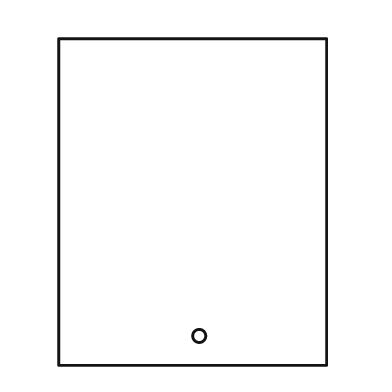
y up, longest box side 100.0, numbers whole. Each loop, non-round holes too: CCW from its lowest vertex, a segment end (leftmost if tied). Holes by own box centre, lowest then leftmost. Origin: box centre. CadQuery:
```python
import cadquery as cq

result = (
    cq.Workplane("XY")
    .moveTo(-41.0, -50.0)
    .lineTo(41.0, -50.0)
    .lineTo(41.0, 50.0)
    .lineTo(-41.0, 50.0)
    .close()
    .moveTo(2.0, -41.0)
    .circle(2.0)
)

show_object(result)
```